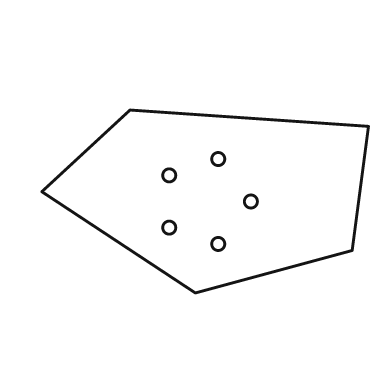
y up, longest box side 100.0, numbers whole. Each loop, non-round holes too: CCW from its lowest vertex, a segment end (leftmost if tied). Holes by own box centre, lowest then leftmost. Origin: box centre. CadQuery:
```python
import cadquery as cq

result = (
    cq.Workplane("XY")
    .moveTo(-3.0, -28.0)
    .lineTo(45.0, -15.0)
    .lineTo(50.0, 23.0)
    .lineTo(-23.0, 28.0)
    .lineTo(-50.0, 3.0)
    .close()
    .moveTo(4.0, -13.0)
    .circle(2.0)
    .moveTo(-11.0, -8.0)
    .circle(2.0)
    .moveTo(14.0, 0.0)
    .circle(2.0)
    .moveTo(-11.0, 8.0)
    .circle(2.0)
    .moveTo(4.0, 13.0)
    .circle(2.0)
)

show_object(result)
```